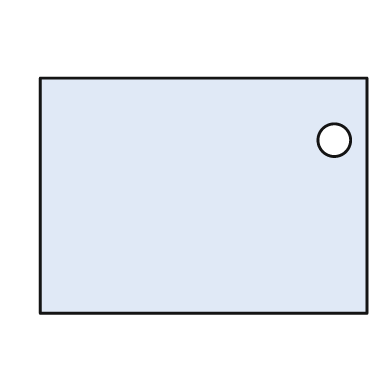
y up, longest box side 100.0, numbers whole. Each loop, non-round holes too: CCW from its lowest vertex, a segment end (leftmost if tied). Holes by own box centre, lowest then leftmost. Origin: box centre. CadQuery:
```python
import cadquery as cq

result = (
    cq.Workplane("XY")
    .moveTo(-50.0, -36.0)
    .lineTo(50.0, -36.0)
    .lineTo(50.0, 36.0)
    .lineTo(-50.0, 36.0)
    .close()
    .moveTo(40.0, 17.0)
    .circle(5.0)
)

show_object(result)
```